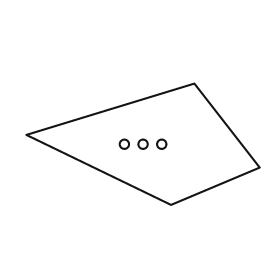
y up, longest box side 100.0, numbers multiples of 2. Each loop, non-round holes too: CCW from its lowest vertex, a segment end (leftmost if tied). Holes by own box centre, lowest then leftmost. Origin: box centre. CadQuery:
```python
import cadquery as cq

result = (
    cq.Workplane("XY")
    .moveTo(12.0, -26.0)
    .lineTo(50.0, -10.0)
    .lineTo(22.0, 26.0)
    .lineTo(-50.0, 4.0)
    .close()
    .moveTo(-8.0, 0.0)
    .circle(2.0)
    .moveTo(0.0, 0.0)
    .circle(2.0)
    .moveTo(8.0, 0.0)
    .circle(2.0)
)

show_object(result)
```